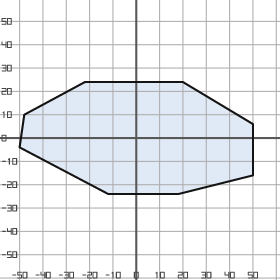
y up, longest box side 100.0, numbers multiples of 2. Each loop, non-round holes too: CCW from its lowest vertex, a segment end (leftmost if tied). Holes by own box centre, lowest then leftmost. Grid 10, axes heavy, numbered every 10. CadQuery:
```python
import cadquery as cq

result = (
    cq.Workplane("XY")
    .moveTo(-12.0, -24.0)
    .lineTo(18.0, -24.0)
    .lineTo(50.0, -16.0)
    .lineTo(50.0, 6.0)
    .lineTo(20.0, 24.0)
    .lineTo(-22.0, 24.0)
    .lineTo(-48.0, 10.0)
    .lineTo(-50.0, -4.0)
    .close()
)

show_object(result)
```